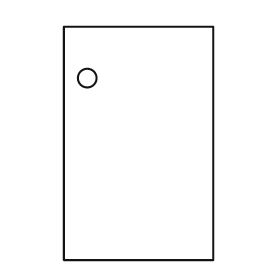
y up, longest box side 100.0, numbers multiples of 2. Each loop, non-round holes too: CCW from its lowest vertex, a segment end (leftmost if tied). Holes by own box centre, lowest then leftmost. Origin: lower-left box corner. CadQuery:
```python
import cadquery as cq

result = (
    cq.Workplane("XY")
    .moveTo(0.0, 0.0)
    .lineTo(64.0, 0.0)
    .lineTo(64.0, 100.0)
    .lineTo(0.0, 100.0)
    .close()
    .moveTo(10.0, 78.0)
    .circle(4.0)
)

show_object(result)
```